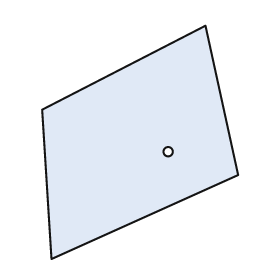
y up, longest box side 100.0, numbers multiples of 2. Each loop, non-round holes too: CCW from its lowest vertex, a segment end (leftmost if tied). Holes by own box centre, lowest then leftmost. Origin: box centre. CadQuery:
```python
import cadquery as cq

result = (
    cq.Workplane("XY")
    .moveTo(-38.0, -50.0)
    .lineTo(42.0, -14.0)
    .lineTo(28.0, 50.0)
    .lineTo(-42.0, 14.0)
    .close()
    .moveTo(12.0, -4.0)
    .circle(2.0)
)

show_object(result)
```